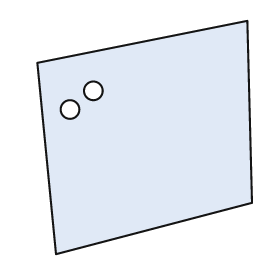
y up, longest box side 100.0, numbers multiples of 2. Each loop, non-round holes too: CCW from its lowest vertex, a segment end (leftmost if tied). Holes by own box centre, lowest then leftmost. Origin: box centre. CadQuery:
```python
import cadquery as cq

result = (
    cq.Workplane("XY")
    .moveTo(-38.0, -50.0)
    .lineTo(46.0, -28.0)
    .lineTo(44.0, 50.0)
    .lineTo(-46.0, 32.0)
    .close()
    .moveTo(-32.0, 12.0)
    .circle(4.0)
    .moveTo(-22.0, 20.0)
    .circle(4.0)
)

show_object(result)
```